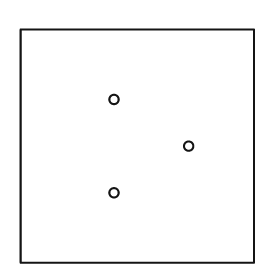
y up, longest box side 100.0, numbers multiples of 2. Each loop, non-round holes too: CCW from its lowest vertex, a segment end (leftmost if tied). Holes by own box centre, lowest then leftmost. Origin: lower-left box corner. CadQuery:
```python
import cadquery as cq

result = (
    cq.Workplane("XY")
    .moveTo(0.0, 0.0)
    .lineTo(100.0, 0.0)
    .lineTo(100.0, 100.0)
    .lineTo(0.0, 100.0)
    .close()
    .moveTo(40.0, 30.0)
    .circle(2.0)
    .moveTo(72.0, 50.0)
    .circle(2.0)
    .moveTo(40.0, 70.0)
    .circle(2.0)
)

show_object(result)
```